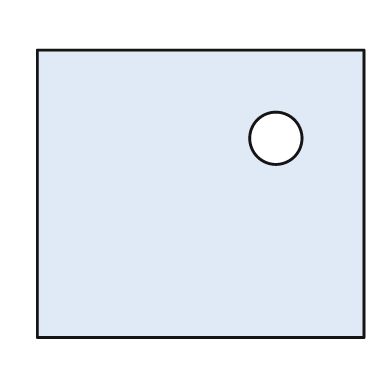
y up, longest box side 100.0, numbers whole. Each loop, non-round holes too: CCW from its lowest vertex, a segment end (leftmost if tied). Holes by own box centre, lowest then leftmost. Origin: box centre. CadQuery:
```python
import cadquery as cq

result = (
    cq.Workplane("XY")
    .moveTo(-50.0, -44.0)
    .lineTo(50.0, -44.0)
    .lineTo(50.0, 44.0)
    .lineTo(-50.0, 44.0)
    .close()
    .moveTo(23.0, 17.0)
    .circle(8.0)
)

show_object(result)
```